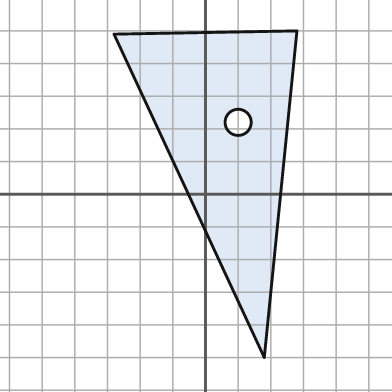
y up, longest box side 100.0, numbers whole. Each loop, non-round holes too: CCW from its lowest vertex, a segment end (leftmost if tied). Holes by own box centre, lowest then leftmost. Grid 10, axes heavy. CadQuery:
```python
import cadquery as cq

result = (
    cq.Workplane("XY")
    .moveTo(18.0, -50.0)
    .lineTo(28.0, 50.0)
    .lineTo(-28.0, 49.0)
    .close()
    .moveTo(10.0, 22.0)
    .circle(4.0)
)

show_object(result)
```